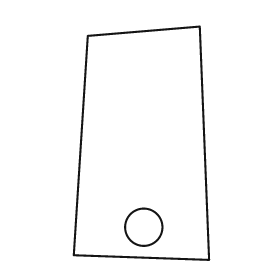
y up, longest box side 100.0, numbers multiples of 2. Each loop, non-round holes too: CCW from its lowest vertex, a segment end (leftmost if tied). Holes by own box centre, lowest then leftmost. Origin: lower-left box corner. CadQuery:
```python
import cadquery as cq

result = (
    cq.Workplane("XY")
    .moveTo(58.0, 0.0)
    .lineTo(54.0, 100.0)
    .lineTo(6.0, 96.0)
    .lineTo(0.0, 2.0)
    .close()
    .moveTo(30.0, 14.0)
    .circle(8.0)
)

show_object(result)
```